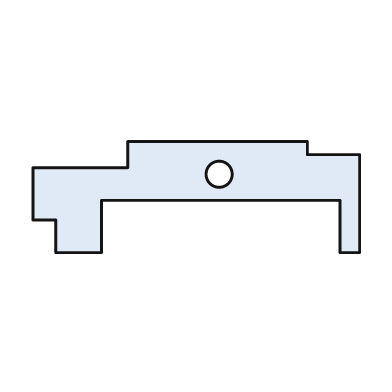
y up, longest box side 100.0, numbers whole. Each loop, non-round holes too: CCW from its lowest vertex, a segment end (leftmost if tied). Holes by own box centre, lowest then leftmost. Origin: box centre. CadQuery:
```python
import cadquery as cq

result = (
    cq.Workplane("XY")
    .moveTo(-43.0, -17.0)
    .lineTo(-29.0, -17.0)
    .lineTo(-29.0, -1.0)
    .lineTo(44.0, -1.0)
    .lineTo(44.0, -17.0)
    .lineTo(50.0, -17.0)
    .lineTo(50.0, 13.0)
    .lineTo(34.0, 13.0)
    .lineTo(34.0, 17.0)
    .lineTo(-21.0, 17.0)
    .lineTo(-21.0, 9.0)
    .lineTo(-50.0, 9.0)
    .lineTo(-50.0, -7.0)
    .lineTo(-43.0, -7.0)
    .close()
    .moveTo(7.0, 7.0)
    .circle(4.0)
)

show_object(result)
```